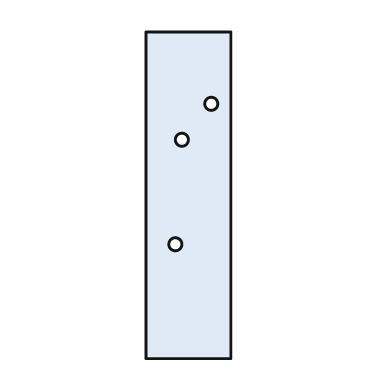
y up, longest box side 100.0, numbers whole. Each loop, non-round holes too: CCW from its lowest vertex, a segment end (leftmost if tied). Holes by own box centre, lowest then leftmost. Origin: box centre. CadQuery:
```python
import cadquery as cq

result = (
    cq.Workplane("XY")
    .moveTo(-13.0, -50.0)
    .lineTo(13.0, -50.0)
    .lineTo(13.0, 50.0)
    .lineTo(-13.0, 50.0)
    .close()
    .moveTo(-4.0, -15.0)
    .circle(2.0)
    .moveTo(-2.0, 17.0)
    .circle(2.0)
    .moveTo(7.0, 28.0)
    .circle(2.0)
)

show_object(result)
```